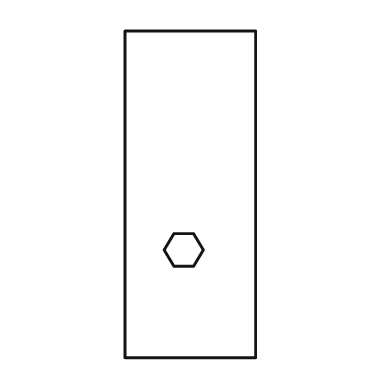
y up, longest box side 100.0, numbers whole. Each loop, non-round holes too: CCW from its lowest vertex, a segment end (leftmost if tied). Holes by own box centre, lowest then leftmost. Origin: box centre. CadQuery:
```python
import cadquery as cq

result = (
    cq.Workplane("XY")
    .moveTo(-20.0, -50.0)
    .lineTo(20.0, -50.0)
    .lineTo(20.0, 50.0)
    .lineTo(-20.0, 50.0)
    .close()
    .moveTo(-5.0, -22.0)
    .lineTo(1.0, -22.0)
    .lineTo(4.0, -17.0)
    .lineTo(1.0, -12.0)
    .lineTo(-5.0, -12.0)
    .lineTo(-8.0, -17.0)
    .close()
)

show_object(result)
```